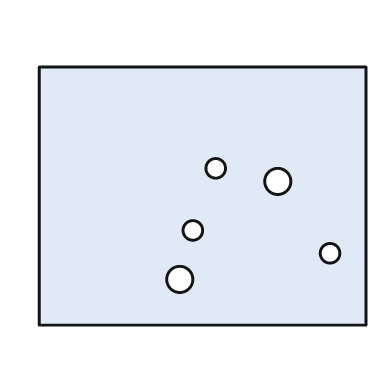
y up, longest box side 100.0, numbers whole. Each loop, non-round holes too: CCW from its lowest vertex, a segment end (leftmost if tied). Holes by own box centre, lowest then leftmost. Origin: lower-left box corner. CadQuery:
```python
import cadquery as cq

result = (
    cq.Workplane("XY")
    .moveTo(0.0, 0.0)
    .lineTo(100.0, 0.0)
    .lineTo(100.0, 79.0)
    .lineTo(0.0, 79.0)
    .close()
    .moveTo(43.0, 14.0)
    .circle(4.0)
    .moveTo(89.0, 22.0)
    .circle(3.0)
    .moveTo(47.0, 29.0)
    .circle(3.0)
    .moveTo(73.0, 44.0)
    .circle(4.0)
    .moveTo(54.0, 48.0)
    .circle(3.0)
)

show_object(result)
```